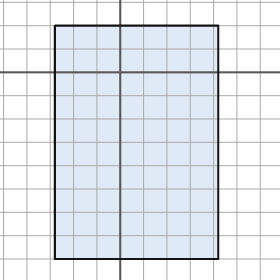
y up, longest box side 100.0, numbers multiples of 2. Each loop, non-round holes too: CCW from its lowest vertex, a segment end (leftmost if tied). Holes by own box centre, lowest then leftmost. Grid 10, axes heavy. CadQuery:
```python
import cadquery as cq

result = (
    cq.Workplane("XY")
    .moveTo(-28.0, -80.0)
    .lineTo(42.0, -80.0)
    .lineTo(42.0, 20.0)
    .lineTo(-28.0, 20.0)
    .close()
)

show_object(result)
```